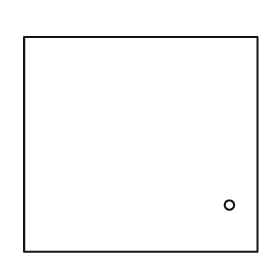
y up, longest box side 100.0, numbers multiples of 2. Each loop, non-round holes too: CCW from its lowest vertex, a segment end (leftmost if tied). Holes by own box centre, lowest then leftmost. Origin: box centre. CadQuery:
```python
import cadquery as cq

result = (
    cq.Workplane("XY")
    .moveTo(-50.0, -46.0)
    .lineTo(50.0, -46.0)
    .lineTo(50.0, 46.0)
    .lineTo(-50.0, 46.0)
    .close()
    .moveTo(38.0, -26.0)
    .circle(2.0)
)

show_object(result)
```